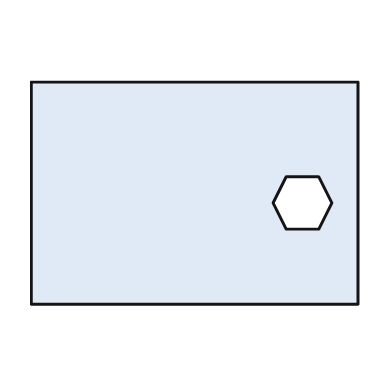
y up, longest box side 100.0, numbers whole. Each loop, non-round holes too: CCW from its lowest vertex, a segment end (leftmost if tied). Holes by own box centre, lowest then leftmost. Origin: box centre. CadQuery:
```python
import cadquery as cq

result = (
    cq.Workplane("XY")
    .moveTo(-50.0, -34.0)
    .lineTo(50.0, -34.0)
    .lineTo(50.0, 34.0)
    .lineTo(-50.0, 34.0)
    .close()
    .moveTo(28.0, -11.0)
    .lineTo(38.0, -11.0)
    .lineTo(42.0, -3.0)
    .lineTo(38.0, 5.0)
    .lineTo(28.0, 5.0)
    .lineTo(24.0, -3.0)
    .close()
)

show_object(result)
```